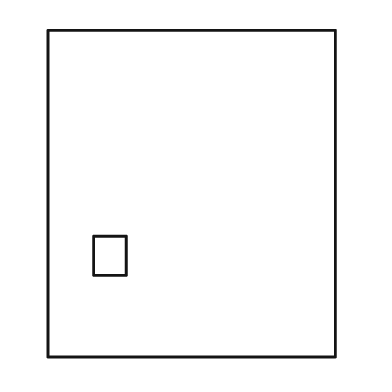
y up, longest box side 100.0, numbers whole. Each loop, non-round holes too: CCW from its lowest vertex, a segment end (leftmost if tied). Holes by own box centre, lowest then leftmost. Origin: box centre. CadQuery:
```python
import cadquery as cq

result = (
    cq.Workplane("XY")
    .moveTo(-44.0, -50.0)
    .lineTo(44.0, -50.0)
    .lineTo(44.0, 50.0)
    .lineTo(-44.0, 50.0)
    .close()
    .moveTo(-30.0, -25.0)
    .lineTo(-20.0, -25.0)
    .lineTo(-20.0, -13.0)
    .lineTo(-30.0, -13.0)
    .close()
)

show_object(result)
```